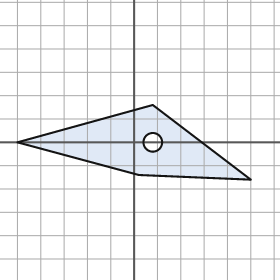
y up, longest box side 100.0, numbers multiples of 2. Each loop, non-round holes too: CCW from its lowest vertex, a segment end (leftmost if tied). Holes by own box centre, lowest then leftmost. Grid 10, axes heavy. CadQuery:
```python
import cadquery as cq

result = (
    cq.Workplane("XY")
    .moveTo(50.0, -16.0)
    .lineTo(8.0, 16.0)
    .lineTo(-50.0, 0.0)
    .lineTo(2.0, -14.0)
    .close()
    .moveTo(8.0, 0.0)
    .circle(4.0)
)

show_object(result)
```